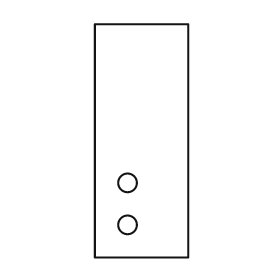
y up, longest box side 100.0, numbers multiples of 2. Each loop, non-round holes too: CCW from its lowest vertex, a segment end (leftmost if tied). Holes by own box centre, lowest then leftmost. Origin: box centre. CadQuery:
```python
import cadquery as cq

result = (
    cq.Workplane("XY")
    .moveTo(-20.0, -50.0)
    .lineTo(20.0, -50.0)
    .lineTo(20.0, 50.0)
    .lineTo(-20.0, 50.0)
    .close()
    .moveTo(-6.0, -36.0)
    .circle(4.0)
    .moveTo(-6.0, -18.0)
    .circle(4.0)
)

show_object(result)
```